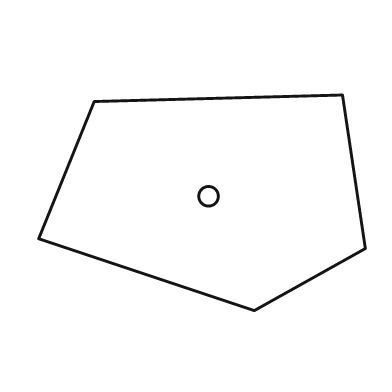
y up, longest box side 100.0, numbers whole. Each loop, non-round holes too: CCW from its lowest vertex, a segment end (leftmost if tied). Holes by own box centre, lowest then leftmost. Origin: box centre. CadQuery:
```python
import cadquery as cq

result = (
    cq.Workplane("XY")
    .moveTo(16.0, -33.0)
    .lineTo(50.0, -14.0)
    .lineTo(43.0, 33.0)
    .lineTo(-33.0, 31.0)
    .lineTo(-50.0, -11.0)
    .close()
    .moveTo(2.0, 2.0)
    .circle(3.0)
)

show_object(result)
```